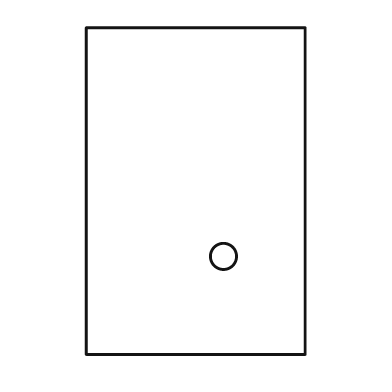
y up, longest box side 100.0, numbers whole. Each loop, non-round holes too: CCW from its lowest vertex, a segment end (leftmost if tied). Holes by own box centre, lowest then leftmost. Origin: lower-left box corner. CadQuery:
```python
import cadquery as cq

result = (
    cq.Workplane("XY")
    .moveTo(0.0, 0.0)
    .lineTo(67.0, 0.0)
    .lineTo(67.0, 100.0)
    .lineTo(0.0, 100.0)
    .close()
    .moveTo(42.0, 30.0)
    .circle(4.0)
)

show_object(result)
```